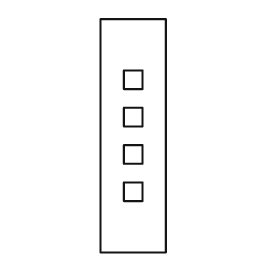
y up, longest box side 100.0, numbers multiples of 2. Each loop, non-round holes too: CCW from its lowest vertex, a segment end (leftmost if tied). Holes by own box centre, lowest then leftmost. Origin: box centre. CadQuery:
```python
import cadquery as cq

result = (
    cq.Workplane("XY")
    .moveTo(-14.0, -50.0)
    .lineTo(14.0, -50.0)
    .lineTo(14.0, 50.0)
    .lineTo(-14.0, 50.0)
    .close()
    .moveTo(-4.0, -28.0)
    .lineTo(4.0, -28.0)
    .lineTo(4.0, -20.0)
    .lineTo(-4.0, -20.0)
    .close()
    .moveTo(-4.0, -12.0)
    .lineTo(4.0, -12.0)
    .lineTo(4.0, -4.0)
    .lineTo(-4.0, -4.0)
    .close()
    .moveTo(-4.0, 4.0)
    .lineTo(4.0, 4.0)
    .lineTo(4.0, 12.0)
    .lineTo(-4.0, 12.0)
    .close()
    .moveTo(-4.0, 20.0)
    .lineTo(4.0, 20.0)
    .lineTo(4.0, 28.0)
    .lineTo(-4.0, 28.0)
    .close()
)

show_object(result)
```